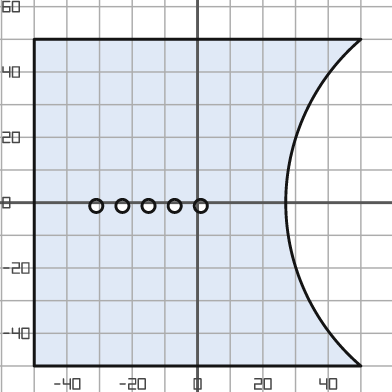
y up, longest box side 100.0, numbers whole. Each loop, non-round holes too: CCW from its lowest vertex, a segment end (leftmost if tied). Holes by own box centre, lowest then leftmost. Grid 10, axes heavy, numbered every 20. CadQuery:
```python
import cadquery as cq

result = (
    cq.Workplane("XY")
    .moveTo(-50.0, -50.0)
    .lineTo(50.0, -50.0)
    .threePointArc((27.0, 0.0), (50.0, 50.0))
    .lineTo(-50.0, 50.0)
    .close()
    .moveTo(-31.0, -1.0)
    .circle(2.0)
    .moveTo(-23.0, -1.0)
    .circle(2.0)
    .moveTo(-15.0, -1.0)
    .circle(2.0)
    .moveTo(-7.0, -1.0)
    .circle(2.0)
    .moveTo(1.0, -1.0)
    .circle(2.0)
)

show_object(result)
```